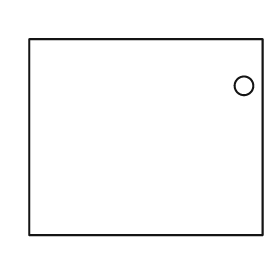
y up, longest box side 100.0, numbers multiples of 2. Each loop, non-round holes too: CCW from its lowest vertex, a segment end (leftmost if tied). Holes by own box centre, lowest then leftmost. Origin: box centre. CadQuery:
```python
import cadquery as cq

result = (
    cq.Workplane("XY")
    .moveTo(-50.0, -42.0)
    .lineTo(50.0, -42.0)
    .lineTo(50.0, 42.0)
    .lineTo(-50.0, 42.0)
    .close()
    .moveTo(42.0, 22.0)
    .circle(4.0)
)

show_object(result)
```